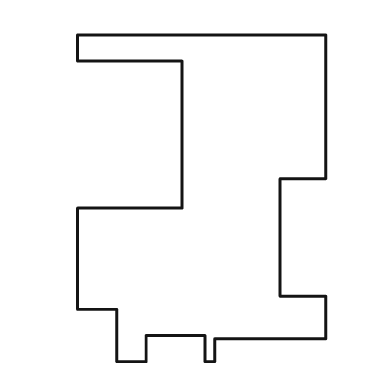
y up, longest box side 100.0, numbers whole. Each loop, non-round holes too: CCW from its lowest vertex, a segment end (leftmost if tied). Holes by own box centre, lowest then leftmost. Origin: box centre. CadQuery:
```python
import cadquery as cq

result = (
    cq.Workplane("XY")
    .moveTo(-26.0, -50.0)
    .lineTo(-17.0, -50.0)
    .lineTo(-17.0, -42.0)
    .lineTo(1.0, -42.0)
    .lineTo(1.0, -50.0)
    .lineTo(4.0, -50.0)
    .lineTo(4.0, -43.0)
    .lineTo(38.0, -43.0)
    .lineTo(38.0, -30.0)
    .lineTo(24.0, -30.0)
    .lineTo(24.0, 6.0)
    .lineTo(38.0, 6.0)
    .lineTo(38.0, 50.0)
    .lineTo(-38.0, 50.0)
    .lineTo(-38.0, 42.0)
    .lineTo(-6.0, 42.0)
    .lineTo(-6.0, -3.0)
    .lineTo(-38.0, -3.0)
    .lineTo(-38.0, -34.0)
    .lineTo(-26.0, -34.0)
    .close()
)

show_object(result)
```